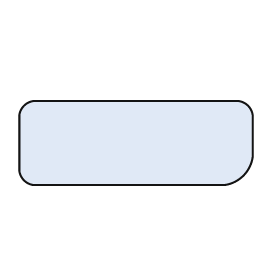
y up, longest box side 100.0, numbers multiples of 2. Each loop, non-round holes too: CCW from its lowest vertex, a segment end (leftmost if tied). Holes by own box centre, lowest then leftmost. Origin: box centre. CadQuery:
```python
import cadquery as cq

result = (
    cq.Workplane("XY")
    .moveTo(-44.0, -18.0)
    .lineTo(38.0, -18.0)
    .threePointArc((46.0, -14.0), (50.0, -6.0))
    .lineTo(50.0, 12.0)
    .threePointArc((48.0, 16.0), (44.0, 18.0))
    .lineTo(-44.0, 18.0)
    .threePointArc((-48.0, 16.0), (-50.0, 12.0))
    .lineTo(-50.0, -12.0)
    .threePointArc((-48.0, -16.0), (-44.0, -18.0))
    .close()
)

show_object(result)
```